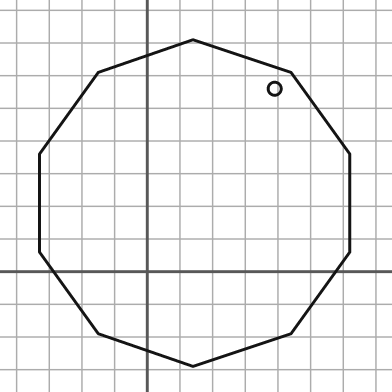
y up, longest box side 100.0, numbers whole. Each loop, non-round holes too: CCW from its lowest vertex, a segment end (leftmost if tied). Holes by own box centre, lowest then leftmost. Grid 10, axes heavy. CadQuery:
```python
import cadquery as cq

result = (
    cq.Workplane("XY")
    .moveTo(14.0, -29.0)
    .lineTo(44.0, -19.0)
    .lineTo(62.0, 6.0)
    .lineTo(62.0, 36.0)
    .lineTo(44.0, 61.0)
    .lineTo(14.0, 71.0)
    .lineTo(-15.0, 61.0)
    .lineTo(-33.0, 36.0)
    .lineTo(-33.0, 6.0)
    .lineTo(-15.0, -19.0)
    .close()
    .moveTo(39.0, 56.0)
    .circle(2.0)
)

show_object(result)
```